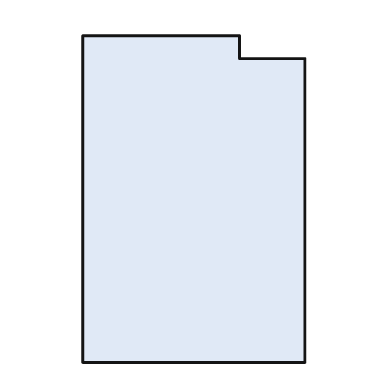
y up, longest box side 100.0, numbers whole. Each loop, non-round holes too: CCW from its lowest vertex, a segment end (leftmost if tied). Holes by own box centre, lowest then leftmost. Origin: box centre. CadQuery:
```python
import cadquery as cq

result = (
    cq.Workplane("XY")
    .moveTo(-34.0, -50.0)
    .lineTo(34.0, -50.0)
    .lineTo(34.0, 43.0)
    .lineTo(14.0, 43.0)
    .lineTo(14.0, 50.0)
    .lineTo(-34.0, 50.0)
    .close()
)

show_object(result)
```